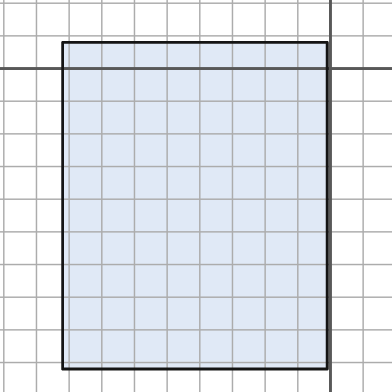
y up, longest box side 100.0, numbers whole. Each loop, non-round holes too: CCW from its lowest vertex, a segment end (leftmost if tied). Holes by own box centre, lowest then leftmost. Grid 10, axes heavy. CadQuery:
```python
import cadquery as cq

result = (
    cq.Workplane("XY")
    .moveTo(-82.0, -92.0)
    .lineTo(-1.0, -92.0)
    .lineTo(-1.0, 8.0)
    .lineTo(-82.0, 8.0)
    .close()
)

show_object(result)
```